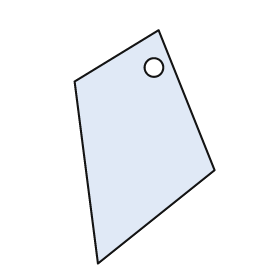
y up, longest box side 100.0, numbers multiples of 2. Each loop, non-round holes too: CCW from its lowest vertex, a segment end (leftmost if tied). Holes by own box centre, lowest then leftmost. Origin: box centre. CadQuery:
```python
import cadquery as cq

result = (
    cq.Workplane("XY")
    .moveTo(-20.0, -50.0)
    .lineTo(30.0, -10.0)
    .lineTo(6.0, 50.0)
    .lineTo(-30.0, 28.0)
    .close()
    .moveTo(4.0, 34.0)
    .circle(4.0)
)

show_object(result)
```